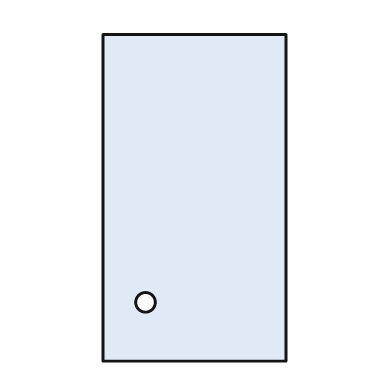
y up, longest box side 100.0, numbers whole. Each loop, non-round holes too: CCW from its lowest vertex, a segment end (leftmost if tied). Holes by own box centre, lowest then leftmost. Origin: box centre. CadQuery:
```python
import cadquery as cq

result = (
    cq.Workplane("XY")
    .moveTo(-28.0, -50.0)
    .lineTo(28.0, -50.0)
    .lineTo(28.0, 50.0)
    .lineTo(-28.0, 50.0)
    .close()
    .moveTo(-15.0, -32.0)
    .circle(3.0)
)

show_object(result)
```